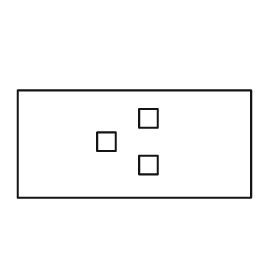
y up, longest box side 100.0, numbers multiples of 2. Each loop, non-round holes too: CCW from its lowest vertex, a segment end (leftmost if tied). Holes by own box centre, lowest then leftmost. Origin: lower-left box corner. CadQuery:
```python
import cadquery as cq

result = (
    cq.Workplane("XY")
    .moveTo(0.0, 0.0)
    .lineTo(100.0, 0.0)
    .lineTo(100.0, 46.0)
    .lineTo(0.0, 46.0)
    .close()
    .moveTo(52.0, 10.0)
    .lineTo(60.0, 10.0)
    .lineTo(60.0, 18.0)
    .lineTo(52.0, 18.0)
    .close()
    .moveTo(34.0, 20.0)
    .lineTo(42.0, 20.0)
    .lineTo(42.0, 28.0)
    .lineTo(34.0, 28.0)
    .close()
    .moveTo(52.0, 30.0)
    .lineTo(60.0, 30.0)
    .lineTo(60.0, 38.0)
    .lineTo(52.0, 38.0)
    .close()
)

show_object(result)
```